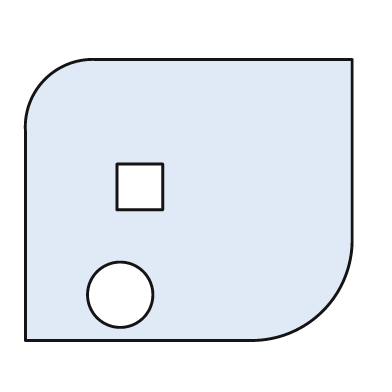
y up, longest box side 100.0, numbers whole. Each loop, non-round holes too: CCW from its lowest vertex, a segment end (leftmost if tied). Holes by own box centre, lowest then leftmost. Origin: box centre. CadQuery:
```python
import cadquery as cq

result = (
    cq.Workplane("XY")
    .moveTo(-50.0, -43.0)
    .lineTo(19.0, -43.0)
    .threePointArc((41.0, -34.0), (50.0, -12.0))
    .lineTo(50.0, 43.0)
    .lineTo(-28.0, 43.0)
    .threePointArc((-44.0, 37.0), (-50.0, 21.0))
    .close()
    .moveTo(-21.0, -29.0)
    .circle(10.0)
    .moveTo(-22.0, -3.0)
    .lineTo(-8.0, -3.0)
    .lineTo(-8.0, 11.0)
    .lineTo(-22.0, 11.0)
    .close()
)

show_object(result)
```